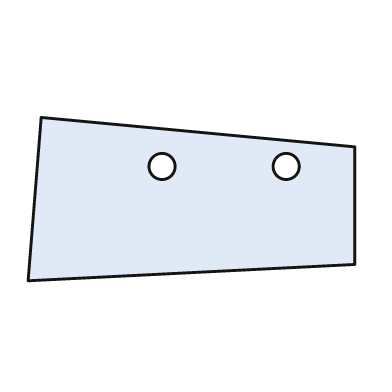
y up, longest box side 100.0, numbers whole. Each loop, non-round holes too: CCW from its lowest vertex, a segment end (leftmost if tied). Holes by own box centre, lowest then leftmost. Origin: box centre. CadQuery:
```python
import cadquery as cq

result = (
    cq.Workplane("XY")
    .moveTo(-50.0, -25.0)
    .lineTo(50.0, -20.0)
    .lineTo(50.0, 16.0)
    .lineTo(-46.0, 25.0)
    .close()
    .moveTo(-9.0, 10.0)
    .circle(4.0)
    .moveTo(29.0, 10.0)
    .circle(4.0)
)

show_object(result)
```